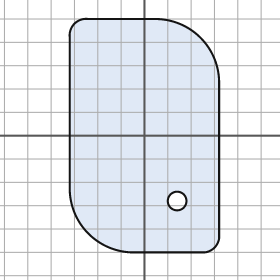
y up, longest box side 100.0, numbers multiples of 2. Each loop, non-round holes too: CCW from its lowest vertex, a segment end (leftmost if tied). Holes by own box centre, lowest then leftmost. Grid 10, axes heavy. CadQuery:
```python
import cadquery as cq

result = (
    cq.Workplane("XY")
    .moveTo(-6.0, -50.0)
    .lineTo(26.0, -50.0)
    .threePointArc((30.0, -48.0), (32.0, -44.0))
    .lineTo(32.0, 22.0)
    .threePointArc((24.0, 42.0), (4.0, 50.0))
    .lineTo(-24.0, 50.0)
    .threePointArc((-30.0, 48.0), (-32.0, 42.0))
    .lineTo(-32.0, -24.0)
    .threePointArc((-24.0, -42.0), (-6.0, -50.0))
    .close()
    .moveTo(14.0, -28.0)
    .circle(4.0)
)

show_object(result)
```